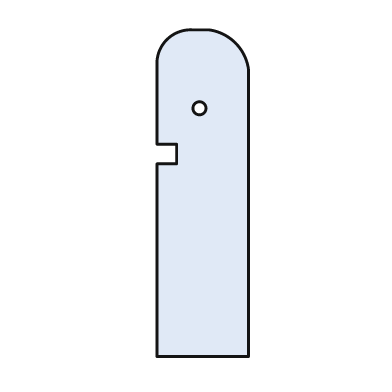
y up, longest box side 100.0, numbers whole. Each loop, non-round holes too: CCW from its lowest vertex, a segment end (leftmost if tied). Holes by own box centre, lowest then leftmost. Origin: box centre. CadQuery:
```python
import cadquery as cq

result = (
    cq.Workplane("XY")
    .moveTo(-14.0, -50.0)
    .lineTo(14.0, -50.0)
    .lineTo(14.0, 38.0)
    .threePointArc((10.0, 46.0), (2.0, 50.0))
    .lineTo(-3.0, 50.0)
    .threePointArc((-11.0, 47.0), (-14.0, 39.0))
    .lineTo(-14.0, 15.0)
    .lineTo(-8.0, 15.0)
    .lineTo(-8.0, 9.0)
    .lineTo(-14.0, 9.0)
    .close()
    .moveTo(-1.0, 26.0)
    .circle(2.0)
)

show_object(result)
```